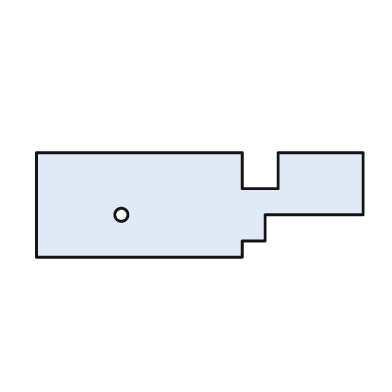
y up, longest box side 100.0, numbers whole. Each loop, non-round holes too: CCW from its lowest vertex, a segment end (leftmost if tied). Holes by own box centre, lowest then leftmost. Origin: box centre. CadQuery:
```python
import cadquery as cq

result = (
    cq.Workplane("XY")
    .moveTo(-50.0, -16.0)
    .lineTo(13.0, -16.0)
    .lineTo(13.0, -11.0)
    .lineTo(20.0, -11.0)
    .lineTo(20.0, -3.0)
    .lineTo(50.0, -3.0)
    .lineTo(50.0, 16.0)
    .lineTo(24.0, 16.0)
    .lineTo(24.0, 5.0)
    .lineTo(13.0, 5.0)
    .lineTo(13.0, 16.0)
    .lineTo(-50.0, 16.0)
    .close()
    .moveTo(-24.0, -3.0)
    .circle(2.0)
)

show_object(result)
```